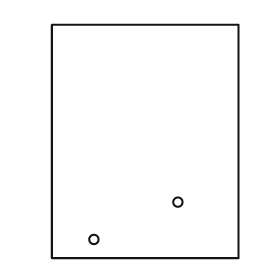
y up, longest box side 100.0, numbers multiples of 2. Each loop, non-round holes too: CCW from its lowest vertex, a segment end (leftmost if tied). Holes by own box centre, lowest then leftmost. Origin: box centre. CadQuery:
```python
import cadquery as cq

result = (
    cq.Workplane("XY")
    .moveTo(-40.0, -50.0)
    .lineTo(40.0, -50.0)
    .lineTo(40.0, 50.0)
    .lineTo(-40.0, 50.0)
    .close()
    .moveTo(-22.0, -42.0)
    .circle(2.0)
    .moveTo(14.0, -26.0)
    .circle(2.0)
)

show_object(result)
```